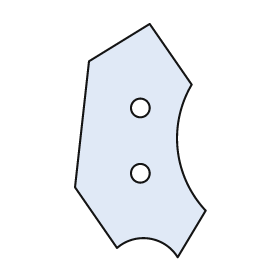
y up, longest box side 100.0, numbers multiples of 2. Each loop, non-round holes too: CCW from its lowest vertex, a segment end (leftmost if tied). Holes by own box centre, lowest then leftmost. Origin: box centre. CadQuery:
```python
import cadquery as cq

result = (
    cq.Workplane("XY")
    .moveTo(16.0, -50.0)
    .lineTo(28.0, -30.0)
    .threePointArc((16.0, -4.0), (22.0, 24.0))
    .lineTo(4.0, 50.0)
    .lineTo(-22.0, 34.0)
    .lineTo(-28.0, -20.0)
    .lineTo(-10.0, -46.0)
    .threePointArc((4.0, -42.0), (16.0, -50.0))
    .close()
    .moveTo(0.0, -14.0)
    .circle(4.0)
    .moveTo(0.0, 14.0)
    .circle(4.0)
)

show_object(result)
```